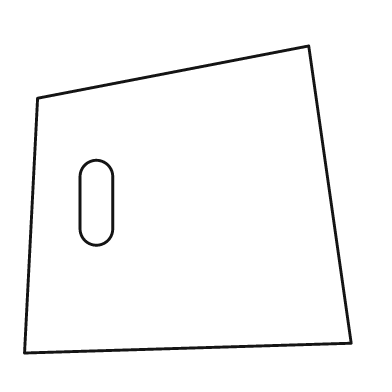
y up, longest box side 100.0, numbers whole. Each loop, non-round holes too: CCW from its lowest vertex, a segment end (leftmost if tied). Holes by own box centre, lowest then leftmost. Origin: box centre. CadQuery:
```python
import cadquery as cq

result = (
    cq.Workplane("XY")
    .moveTo(-50.0, -47.0)
    .lineTo(50.0, -44.0)
    .lineTo(37.0, 47.0)
    .lineTo(-46.0, 31.0)
    .close()
    .moveTo(-33.0, -9.0)
    .threePointArc((-28.0, -14.0), (-23.0, -9.0))
    .lineTo(-23.0, 7.0)
    .threePointArc((-28.0, 12.0), (-33.0, 7.0))
    .close()
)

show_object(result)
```